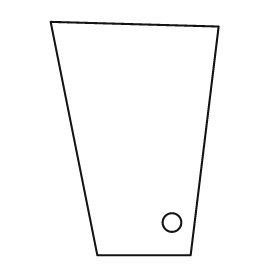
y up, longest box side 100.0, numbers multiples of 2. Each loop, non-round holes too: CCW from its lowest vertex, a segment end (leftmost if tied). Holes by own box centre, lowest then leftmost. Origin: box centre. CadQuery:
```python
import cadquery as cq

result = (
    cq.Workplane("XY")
    .moveTo(-16.0, -50.0)
    .lineTo(24.0, -50.0)
    .lineTo(36.0, 48.0)
    .lineTo(-36.0, 50.0)
    .close()
    .moveTo(16.0, -36.0)
    .circle(4.0)
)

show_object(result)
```